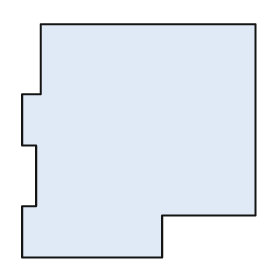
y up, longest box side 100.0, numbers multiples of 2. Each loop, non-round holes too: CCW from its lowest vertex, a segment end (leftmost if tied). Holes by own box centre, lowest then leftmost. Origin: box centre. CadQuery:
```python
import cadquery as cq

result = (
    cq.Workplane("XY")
    .moveTo(-50.0, -50.0)
    .lineTo(10.0, -50.0)
    .lineTo(10.0, -32.0)
    .lineTo(50.0, -32.0)
    .lineTo(50.0, 50.0)
    .lineTo(-42.0, 50.0)
    .lineTo(-42.0, 20.0)
    .lineTo(-50.0, 20.0)
    .lineTo(-50.0, -2.0)
    .lineTo(-44.0, -2.0)
    .lineTo(-44.0, -28.0)
    .lineTo(-50.0, -28.0)
    .close()
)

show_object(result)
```